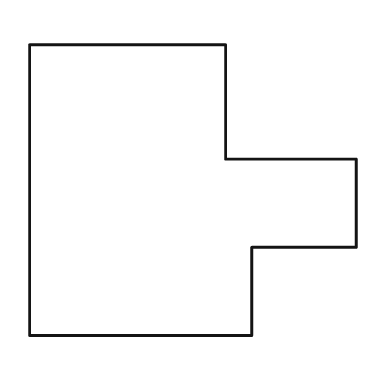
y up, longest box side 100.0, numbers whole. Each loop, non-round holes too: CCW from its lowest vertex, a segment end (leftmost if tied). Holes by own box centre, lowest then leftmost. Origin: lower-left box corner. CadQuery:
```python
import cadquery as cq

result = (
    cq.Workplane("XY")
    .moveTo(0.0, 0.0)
    .lineTo(68.0, 0.0)
    .lineTo(68.0, 27.0)
    .lineTo(100.0, 27.0)
    .lineTo(100.0, 54.0)
    .lineTo(60.0, 54.0)
    .lineTo(60.0, 89.0)
    .lineTo(0.0, 89.0)
    .close()
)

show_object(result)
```